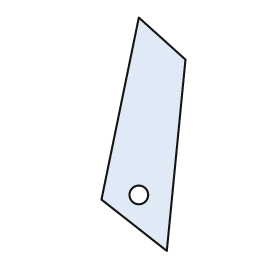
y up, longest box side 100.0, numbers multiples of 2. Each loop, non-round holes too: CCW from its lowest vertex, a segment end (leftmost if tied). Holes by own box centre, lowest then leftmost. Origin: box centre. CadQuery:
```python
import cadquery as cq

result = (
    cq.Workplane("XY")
    .moveTo(10.0, -50.0)
    .lineTo(18.0, 32.0)
    .lineTo(-2.0, 50.0)
    .lineTo(-18.0, -28.0)
    .close()
    .moveTo(-2.0, -26.0)
    .circle(4.0)
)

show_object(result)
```